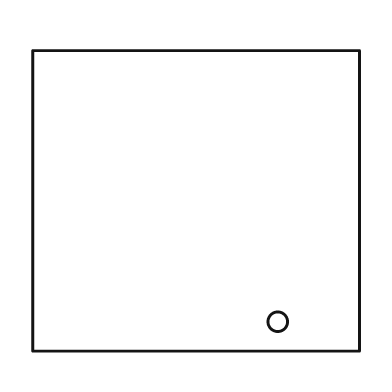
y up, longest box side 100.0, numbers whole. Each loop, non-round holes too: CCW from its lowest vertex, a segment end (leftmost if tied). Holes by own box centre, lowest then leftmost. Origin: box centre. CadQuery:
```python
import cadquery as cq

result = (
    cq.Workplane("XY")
    .moveTo(-50.0, -46.0)
    .lineTo(50.0, -46.0)
    .lineTo(50.0, 46.0)
    .lineTo(-50.0, 46.0)
    .close()
    .moveTo(25.0, -37.0)
    .circle(3.0)
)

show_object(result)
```